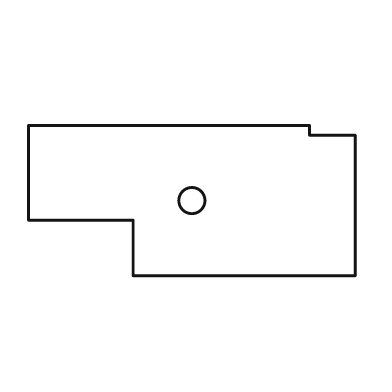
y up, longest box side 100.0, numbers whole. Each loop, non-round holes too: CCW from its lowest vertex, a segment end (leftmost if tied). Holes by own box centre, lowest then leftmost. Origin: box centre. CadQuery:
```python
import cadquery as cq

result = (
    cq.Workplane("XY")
    .moveTo(-18.0, -23.0)
    .lineTo(50.0, -23.0)
    .lineTo(50.0, 20.0)
    .lineTo(36.0, 20.0)
    .lineTo(36.0, 23.0)
    .lineTo(-50.0, 23.0)
    .lineTo(-50.0, -6.0)
    .lineTo(-18.0, -6.0)
    .close()
    .moveTo(0.0, 0.0)
    .circle(4.0)
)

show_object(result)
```